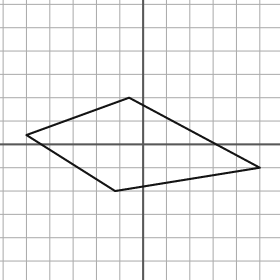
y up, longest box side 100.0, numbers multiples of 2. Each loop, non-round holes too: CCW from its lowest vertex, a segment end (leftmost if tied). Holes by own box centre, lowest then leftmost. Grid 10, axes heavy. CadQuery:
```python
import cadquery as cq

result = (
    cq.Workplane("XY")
    .moveTo(-12.0, -20.0)
    .lineTo(50.0, -10.0)
    .lineTo(-6.0, 20.0)
    .lineTo(-50.0, 4.0)
    .close()
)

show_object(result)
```